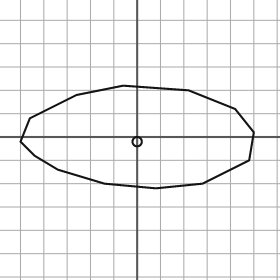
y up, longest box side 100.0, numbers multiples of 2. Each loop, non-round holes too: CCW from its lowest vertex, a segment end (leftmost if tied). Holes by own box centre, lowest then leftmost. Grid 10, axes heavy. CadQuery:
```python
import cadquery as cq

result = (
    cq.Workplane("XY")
    .moveTo(8.0, -22.0)
    .lineTo(28.0, -20.0)
    .lineTo(48.0, -10.0)
    .lineTo(50.0, 2.0)
    .lineTo(42.0, 12.0)
    .lineTo(22.0, 20.0)
    .lineTo(-6.0, 22.0)
    .lineTo(-26.0, 18.0)
    .lineTo(-46.0, 8.0)
    .lineTo(-50.0, -2.0)
    .lineTo(-44.0, -8.0)
    .lineTo(-34.0, -14.0)
    .lineTo(-14.0, -20.0)
    .close()
    .moveTo(0.0, -2.0)
    .circle(2.0)
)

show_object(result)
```